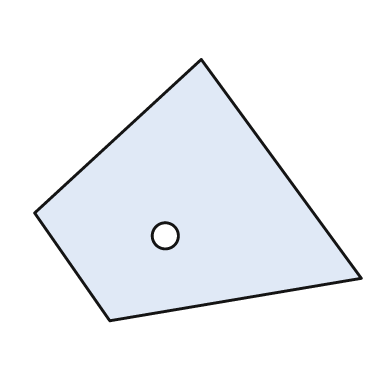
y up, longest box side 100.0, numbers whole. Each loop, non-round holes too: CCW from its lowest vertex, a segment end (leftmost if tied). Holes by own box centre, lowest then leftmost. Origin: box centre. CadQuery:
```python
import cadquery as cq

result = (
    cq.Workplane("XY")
    .moveTo(-27.0, -40.0)
    .lineTo(50.0, -27.0)
    .lineTo(1.0, 40.0)
    .lineTo(-50.0, -7.0)
    .close()
    .moveTo(-10.0, -14.0)
    .circle(4.0)
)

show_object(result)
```